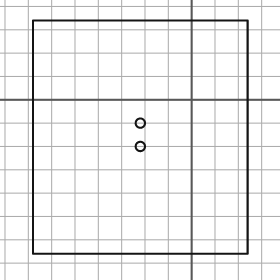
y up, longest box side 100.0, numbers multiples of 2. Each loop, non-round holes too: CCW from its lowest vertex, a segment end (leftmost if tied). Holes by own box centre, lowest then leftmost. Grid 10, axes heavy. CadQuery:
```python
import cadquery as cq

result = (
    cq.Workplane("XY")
    .moveTo(-68.0, -66.0)
    .lineTo(24.0, -66.0)
    .lineTo(24.0, 34.0)
    .lineTo(-68.0, 34.0)
    .close()
    .moveTo(-22.0, -20.0)
    .circle(2.0)
    .moveTo(-22.0, -10.0)
    .circle(2.0)
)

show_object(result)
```